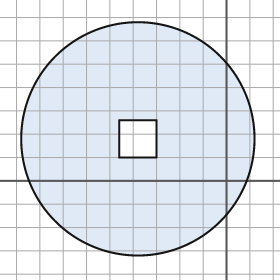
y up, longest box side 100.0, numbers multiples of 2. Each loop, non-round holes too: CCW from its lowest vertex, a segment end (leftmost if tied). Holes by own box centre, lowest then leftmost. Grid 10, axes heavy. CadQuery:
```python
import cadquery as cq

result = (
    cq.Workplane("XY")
    .moveTo(-38.0, 18.0)
    .circle(50.0)
    .moveTo(-46.0, 10.0)
    .lineTo(-30.0, 10.0)
    .lineTo(-30.0, 26.0)
    .lineTo(-46.0, 26.0)
    .close()
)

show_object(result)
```